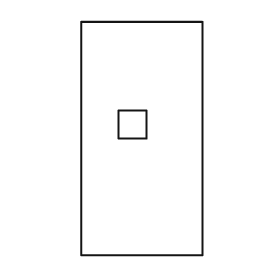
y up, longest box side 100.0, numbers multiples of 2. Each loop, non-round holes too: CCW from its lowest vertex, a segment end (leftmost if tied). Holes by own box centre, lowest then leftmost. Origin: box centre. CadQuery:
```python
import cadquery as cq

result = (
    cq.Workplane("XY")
    .moveTo(-26.0, -50.0)
    .lineTo(26.0, -50.0)
    .lineTo(26.0, 50.0)
    .lineTo(-26.0, 50.0)
    .close()
    .moveTo(-10.0, 0.0)
    .lineTo(2.0, 0.0)
    .lineTo(2.0, 12.0)
    .lineTo(-10.0, 12.0)
    .close()
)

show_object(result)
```